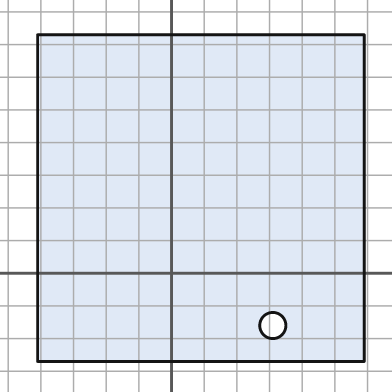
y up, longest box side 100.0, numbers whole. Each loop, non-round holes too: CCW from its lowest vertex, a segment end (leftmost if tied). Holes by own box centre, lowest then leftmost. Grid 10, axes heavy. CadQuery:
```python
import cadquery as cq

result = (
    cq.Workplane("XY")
    .moveTo(-41.0, -27.0)
    .lineTo(59.0, -27.0)
    .lineTo(59.0, 73.0)
    .lineTo(-41.0, 73.0)
    .close()
    .moveTo(31.0, -16.0)
    .circle(4.0)
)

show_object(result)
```